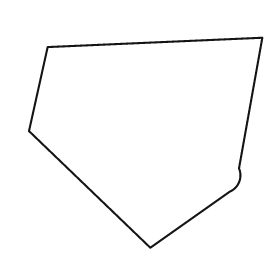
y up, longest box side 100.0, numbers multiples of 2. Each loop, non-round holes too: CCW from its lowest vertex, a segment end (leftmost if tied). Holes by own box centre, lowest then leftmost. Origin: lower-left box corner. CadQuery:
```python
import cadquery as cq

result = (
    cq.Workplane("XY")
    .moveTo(52.0, 0.0)
    .lineTo(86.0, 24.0)
    .threePointArc((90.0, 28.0), (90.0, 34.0))
    .lineTo(100.0, 90.0)
    .lineTo(8.0, 86.0)
    .lineTo(0.0, 50.0)
    .close()
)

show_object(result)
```